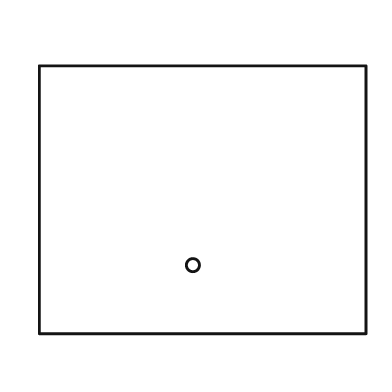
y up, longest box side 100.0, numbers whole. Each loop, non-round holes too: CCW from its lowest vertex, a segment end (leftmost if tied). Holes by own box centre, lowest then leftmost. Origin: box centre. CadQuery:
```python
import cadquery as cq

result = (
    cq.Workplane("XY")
    .moveTo(-50.0, -41.0)
    .lineTo(50.0, -41.0)
    .lineTo(50.0, 41.0)
    .lineTo(-50.0, 41.0)
    .close()
    .moveTo(-3.0, -20.0)
    .circle(2.0)
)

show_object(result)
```